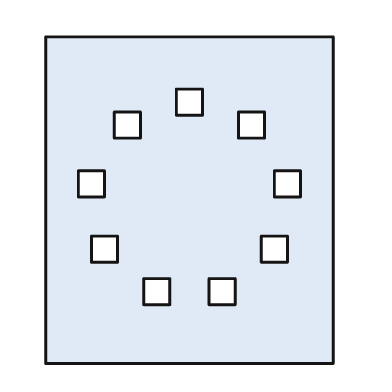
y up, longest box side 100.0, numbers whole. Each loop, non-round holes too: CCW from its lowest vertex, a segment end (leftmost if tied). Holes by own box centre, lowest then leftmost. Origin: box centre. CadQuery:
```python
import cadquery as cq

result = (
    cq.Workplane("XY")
    .moveTo(-44.0, -50.0)
    .lineTo(44.0, -50.0)
    .lineTo(44.0, 50.0)
    .lineTo(-44.0, 50.0)
    .close()
    .moveTo(-14.0, -32.0)
    .lineTo(-6.0, -32.0)
    .lineTo(-6.0, -24.0)
    .lineTo(-14.0, -24.0)
    .close()
    .moveTo(6.0, -32.0)
    .lineTo(14.0, -32.0)
    .lineTo(14.0, -24.0)
    .lineTo(6.0, -24.0)
    .close()
    .moveTo(-30.0, -19.0)
    .lineTo(-22.0, -19.0)
    .lineTo(-22.0, -11.0)
    .lineTo(-30.0, -11.0)
    .close()
    .moveTo(22.0, -19.0)
    .lineTo(30.0, -19.0)
    .lineTo(30.0, -11.0)
    .lineTo(22.0, -11.0)
    .close()
    .moveTo(-34.0, 1.0)
    .lineTo(-26.0, 1.0)
    .lineTo(-26.0, 9.0)
    .lineTo(-34.0, 9.0)
    .close()
    .moveTo(26.0, 1.0)
    .lineTo(34.0, 1.0)
    .lineTo(34.0, 9.0)
    .lineTo(26.0, 9.0)
    .close()
    .moveTo(-23.0, 19.0)
    .lineTo(-15.0, 19.0)
    .lineTo(-15.0, 27.0)
    .lineTo(-23.0, 27.0)
    .close()
    .moveTo(15.0, 19.0)
    .lineTo(23.0, 19.0)
    .lineTo(23.0, 27.0)
    .lineTo(15.0, 27.0)
    .close()
    .moveTo(-4.0, 26.0)
    .lineTo(4.0, 26.0)
    .lineTo(4.0, 34.0)
    .lineTo(-4.0, 34.0)
    .close()
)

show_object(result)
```